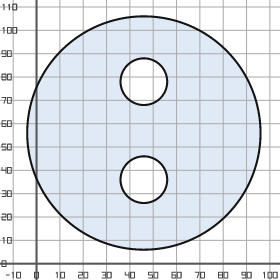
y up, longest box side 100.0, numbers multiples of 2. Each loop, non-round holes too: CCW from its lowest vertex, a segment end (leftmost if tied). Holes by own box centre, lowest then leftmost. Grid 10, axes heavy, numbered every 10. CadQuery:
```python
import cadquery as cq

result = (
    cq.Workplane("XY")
    .moveTo(46.0, 56.0)
    .circle(50.0)
    .moveTo(46.0, 36.0)
    .circle(10.0)
    .moveTo(46.0, 78.0)
    .circle(10.0)
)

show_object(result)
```